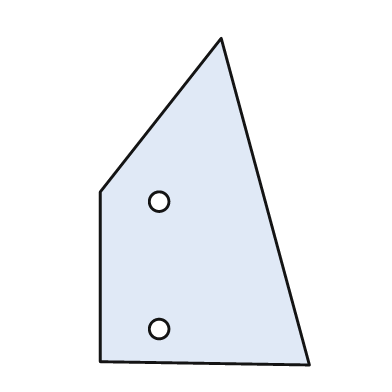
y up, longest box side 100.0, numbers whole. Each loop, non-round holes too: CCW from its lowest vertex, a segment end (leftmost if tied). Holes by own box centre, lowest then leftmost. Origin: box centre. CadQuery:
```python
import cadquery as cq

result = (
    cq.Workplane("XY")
    .moveTo(32.0, -50.0)
    .lineTo(5.0, 50.0)
    .lineTo(-32.0, 3.0)
    .lineTo(-32.0, -49.0)
    .close()
    .moveTo(-14.0, -39.0)
    .circle(3.0)
    .moveTo(-14.0, 0.0)
    .circle(3.0)
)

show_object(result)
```